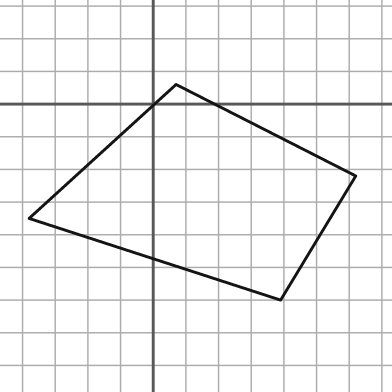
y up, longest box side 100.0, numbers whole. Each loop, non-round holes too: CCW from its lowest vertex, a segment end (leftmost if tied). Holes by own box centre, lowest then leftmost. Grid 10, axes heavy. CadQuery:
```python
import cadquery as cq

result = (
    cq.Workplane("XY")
    .moveTo(39.0, -60.0)
    .lineTo(62.0, -22.0)
    .lineTo(7.0, 6.0)
    .lineTo(-38.0, -35.0)
    .close()
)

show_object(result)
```